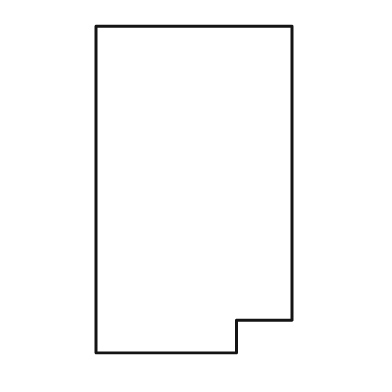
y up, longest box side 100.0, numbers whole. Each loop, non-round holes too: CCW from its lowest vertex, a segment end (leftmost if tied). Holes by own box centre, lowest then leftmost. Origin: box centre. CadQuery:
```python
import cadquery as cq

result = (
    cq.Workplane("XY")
    .moveTo(-30.0, -50.0)
    .lineTo(13.0, -50.0)
    .lineTo(13.0, -40.0)
    .lineTo(30.0, -40.0)
    .lineTo(30.0, 50.0)
    .lineTo(-30.0, 50.0)
    .close()
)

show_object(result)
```